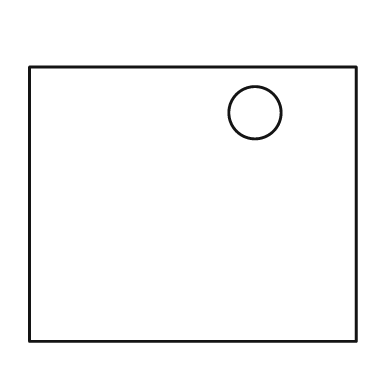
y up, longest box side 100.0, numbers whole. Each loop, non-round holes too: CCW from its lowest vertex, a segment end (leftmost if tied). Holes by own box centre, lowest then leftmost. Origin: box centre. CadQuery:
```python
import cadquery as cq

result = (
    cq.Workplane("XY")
    .moveTo(-50.0, -42.0)
    .lineTo(50.0, -42.0)
    .lineTo(50.0, 42.0)
    .lineTo(-50.0, 42.0)
    .close()
    .moveTo(19.0, 28.0)
    .circle(8.0)
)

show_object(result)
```